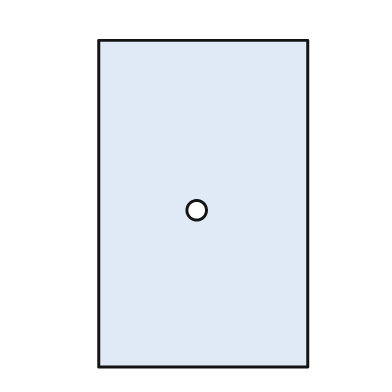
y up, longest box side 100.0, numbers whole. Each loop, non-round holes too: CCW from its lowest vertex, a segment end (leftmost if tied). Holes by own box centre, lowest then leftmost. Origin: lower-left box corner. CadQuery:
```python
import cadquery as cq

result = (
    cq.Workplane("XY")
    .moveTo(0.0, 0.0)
    .lineTo(64.0, 0.0)
    .lineTo(64.0, 100.0)
    .lineTo(0.0, 100.0)
    .close()
    .moveTo(30.0, 48.0)
    .circle(3.0)
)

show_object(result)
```